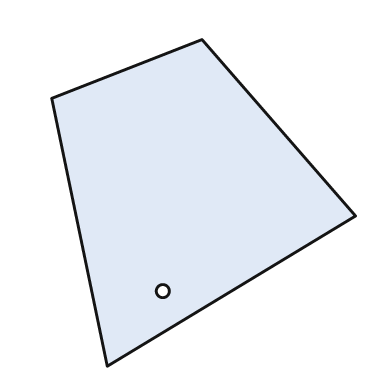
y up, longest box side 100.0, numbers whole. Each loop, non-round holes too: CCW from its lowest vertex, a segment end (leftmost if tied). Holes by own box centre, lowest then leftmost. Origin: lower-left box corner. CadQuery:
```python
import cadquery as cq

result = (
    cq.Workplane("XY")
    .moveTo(17.0, 0.0)
    .lineTo(93.0, 46.0)
    .lineTo(46.0, 100.0)
    .lineTo(0.0, 82.0)
    .close()
    .moveTo(34.0, 23.0)
    .circle(2.0)
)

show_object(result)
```